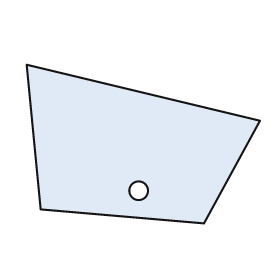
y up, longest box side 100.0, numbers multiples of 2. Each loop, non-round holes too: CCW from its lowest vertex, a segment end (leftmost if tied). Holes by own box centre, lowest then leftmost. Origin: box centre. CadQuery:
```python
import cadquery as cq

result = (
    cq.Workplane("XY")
    .moveTo(26.0, -34.0)
    .lineTo(50.0, 10.0)
    .lineTo(-50.0, 34.0)
    .lineTo(-44.0, -28.0)
    .close()
    .moveTo(-2.0, -20.0)
    .circle(4.0)
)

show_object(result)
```